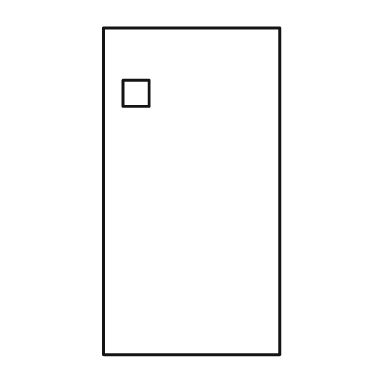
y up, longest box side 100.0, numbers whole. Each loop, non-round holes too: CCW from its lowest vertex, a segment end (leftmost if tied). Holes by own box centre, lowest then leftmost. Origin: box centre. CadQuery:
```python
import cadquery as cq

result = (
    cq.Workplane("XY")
    .moveTo(-27.0, -50.0)
    .lineTo(27.0, -50.0)
    .lineTo(27.0, 50.0)
    .lineTo(-27.0, 50.0)
    .close()
    .moveTo(-21.0, 26.0)
    .lineTo(-13.0, 26.0)
    .lineTo(-13.0, 34.0)
    .lineTo(-21.0, 34.0)
    .close()
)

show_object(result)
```